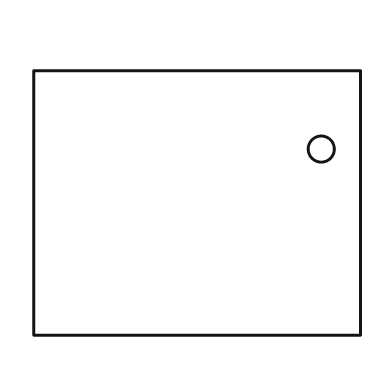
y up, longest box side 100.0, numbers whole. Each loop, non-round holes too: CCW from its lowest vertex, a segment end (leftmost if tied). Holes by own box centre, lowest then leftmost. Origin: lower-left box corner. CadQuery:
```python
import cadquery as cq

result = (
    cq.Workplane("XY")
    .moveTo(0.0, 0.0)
    .lineTo(100.0, 0.0)
    .lineTo(100.0, 81.0)
    .lineTo(0.0, 81.0)
    .close()
    .moveTo(88.0, 57.0)
    .circle(4.0)
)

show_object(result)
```